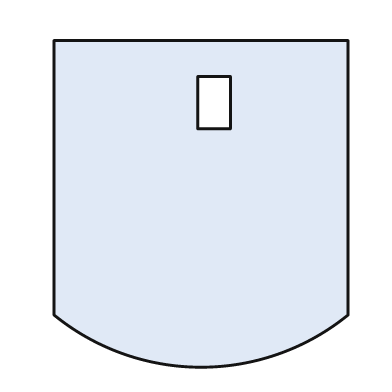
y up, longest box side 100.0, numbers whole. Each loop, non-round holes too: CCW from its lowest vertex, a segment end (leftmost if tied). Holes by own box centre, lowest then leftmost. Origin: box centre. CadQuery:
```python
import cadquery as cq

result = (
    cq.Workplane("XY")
    .moveTo(-45.0, -34.0)
    .threePointArc((0.0, -50.0), (45.0, -34.0))
    .lineTo(45.0, 50.0)
    .lineTo(-45.0, 50.0)
    .close()
    .moveTo(-1.0, 23.0)
    .lineTo(9.0, 23.0)
    .lineTo(9.0, 39.0)
    .lineTo(-1.0, 39.0)
    .close()
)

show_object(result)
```